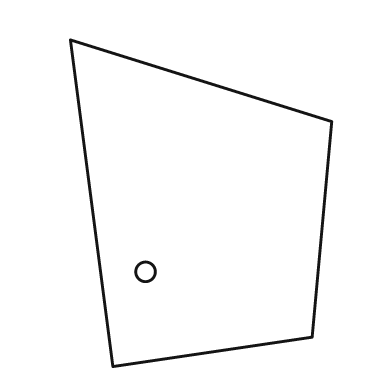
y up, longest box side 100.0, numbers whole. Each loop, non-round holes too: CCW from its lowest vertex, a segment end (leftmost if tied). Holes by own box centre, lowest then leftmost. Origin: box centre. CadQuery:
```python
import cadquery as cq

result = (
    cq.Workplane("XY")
    .moveTo(-27.0, -50.0)
    .lineTo(34.0, -41.0)
    .lineTo(40.0, 25.0)
    .lineTo(-40.0, 50.0)
    .close()
    .moveTo(-17.0, -21.0)
    .circle(3.0)
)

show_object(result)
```